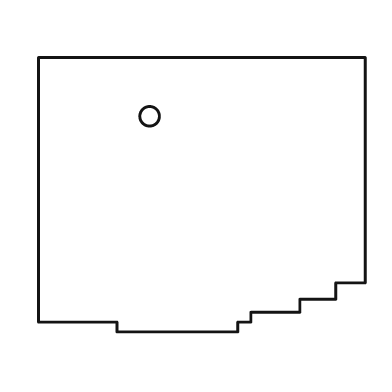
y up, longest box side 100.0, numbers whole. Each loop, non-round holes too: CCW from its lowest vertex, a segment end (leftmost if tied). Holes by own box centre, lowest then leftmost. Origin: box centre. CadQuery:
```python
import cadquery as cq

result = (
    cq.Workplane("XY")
    .moveTo(-26.0, -42.0)
    .lineTo(11.0, -42.0)
    .lineTo(11.0, -39.0)
    .lineTo(15.0, -39.0)
    .lineTo(15.0, -36.0)
    .lineTo(30.0, -36.0)
    .lineTo(30.0, -32.0)
    .lineTo(41.0, -32.0)
    .lineTo(41.0, -27.0)
    .lineTo(50.0, -27.0)
    .lineTo(50.0, 42.0)
    .lineTo(-50.0, 42.0)
    .lineTo(-50.0, -39.0)
    .lineTo(-26.0, -39.0)
    .close()
    .moveTo(-16.0, 24.0)
    .circle(3.0)
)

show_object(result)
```